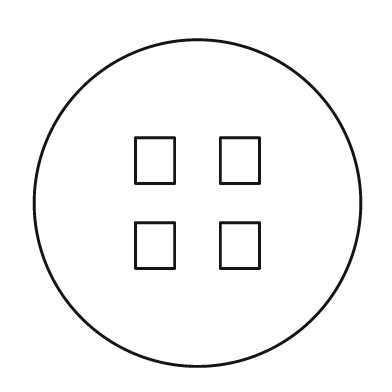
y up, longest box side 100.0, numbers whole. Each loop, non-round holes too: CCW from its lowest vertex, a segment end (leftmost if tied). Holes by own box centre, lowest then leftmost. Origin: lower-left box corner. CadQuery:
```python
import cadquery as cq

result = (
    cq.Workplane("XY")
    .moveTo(50.0, 50.0)
    .circle(50.0)
    .moveTo(31.0, 30.0)
    .lineTo(43.0, 30.0)
    .lineTo(43.0, 44.0)
    .lineTo(31.0, 44.0)
    .close()
    .moveTo(57.0, 30.0)
    .lineTo(69.0, 30.0)
    .lineTo(69.0, 44.0)
    .lineTo(57.0, 44.0)
    .close()
    .moveTo(31.0, 56.0)
    .lineTo(43.0, 56.0)
    .lineTo(43.0, 70.0)
    .lineTo(31.0, 70.0)
    .close()
    .moveTo(57.0, 56.0)
    .lineTo(69.0, 56.0)
    .lineTo(69.0, 70.0)
    .lineTo(57.0, 70.0)
    .close()
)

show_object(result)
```